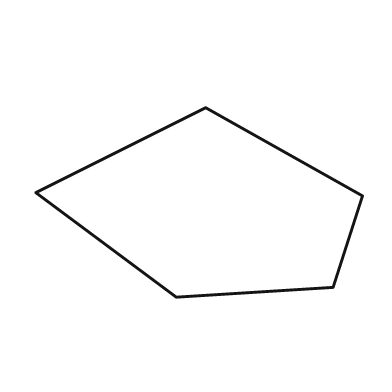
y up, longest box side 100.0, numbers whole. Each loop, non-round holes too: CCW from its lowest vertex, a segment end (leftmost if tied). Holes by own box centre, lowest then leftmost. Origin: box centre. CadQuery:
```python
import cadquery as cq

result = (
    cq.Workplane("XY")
    .moveTo(-7.0, -29.0)
    .lineTo(41.0, -26.0)
    .lineTo(50.0, 2.0)
    .lineTo(2.0, 29.0)
    .lineTo(-50.0, 3.0)
    .close()
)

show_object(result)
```